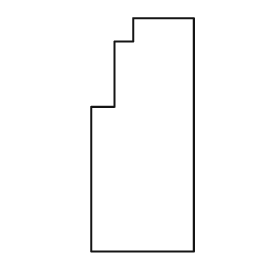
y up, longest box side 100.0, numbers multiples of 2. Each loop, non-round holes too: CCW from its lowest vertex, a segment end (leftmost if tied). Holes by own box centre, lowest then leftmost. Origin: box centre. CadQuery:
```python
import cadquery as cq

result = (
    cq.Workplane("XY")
    .moveTo(-22.0, -50.0)
    .lineTo(22.0, -50.0)
    .lineTo(22.0, 50.0)
    .lineTo(-4.0, 50.0)
    .lineTo(-4.0, 40.0)
    .lineTo(-12.0, 40.0)
    .lineTo(-12.0, 12.0)
    .lineTo(-22.0, 12.0)
    .close()
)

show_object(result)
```